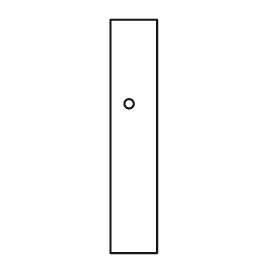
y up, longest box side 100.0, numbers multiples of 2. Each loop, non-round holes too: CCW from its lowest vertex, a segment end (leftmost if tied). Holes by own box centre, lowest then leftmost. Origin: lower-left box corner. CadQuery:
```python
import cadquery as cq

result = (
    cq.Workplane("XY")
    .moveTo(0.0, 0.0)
    .lineTo(20.0, 0.0)
    .lineTo(20.0, 100.0)
    .lineTo(0.0, 100.0)
    .close()
    .moveTo(8.0, 64.0)
    .circle(2.0)
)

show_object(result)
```